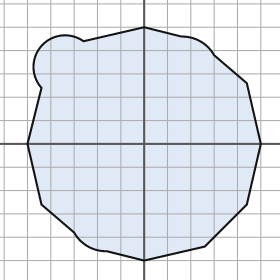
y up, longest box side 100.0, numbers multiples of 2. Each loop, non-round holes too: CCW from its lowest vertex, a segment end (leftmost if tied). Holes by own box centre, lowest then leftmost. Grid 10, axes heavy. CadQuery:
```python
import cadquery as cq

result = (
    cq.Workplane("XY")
    .moveTo(0.0, -50.0)
    .lineTo(26.0, -44.0)
    .lineTo(44.0, -26.0)
    .lineTo(50.0, 0.0)
    .lineTo(44.0, 26.0)
    .lineTo(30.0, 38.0)
    .threePointArc((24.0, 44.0), (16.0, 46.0))
    .lineTo(0.0, 50.0)
    .lineTo(-26.0, 44.0)
    .threePointArc((-44.0, 42.0), (-44.0, 24.0))
    .lineTo(-50.0, 0.0)
    .lineTo(-44.0, -26.0)
    .lineTo(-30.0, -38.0)
    .threePointArc((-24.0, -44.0), (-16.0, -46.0))
    .close()
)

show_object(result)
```